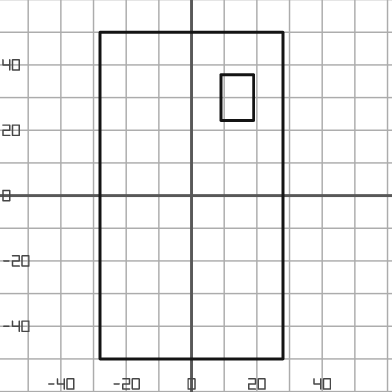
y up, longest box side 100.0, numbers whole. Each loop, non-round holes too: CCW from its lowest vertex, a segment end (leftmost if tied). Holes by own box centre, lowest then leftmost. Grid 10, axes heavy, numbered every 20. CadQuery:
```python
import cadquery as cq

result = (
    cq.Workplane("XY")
    .moveTo(-28.0, -50.0)
    .lineTo(28.0, -50.0)
    .lineTo(28.0, 50.0)
    .lineTo(-28.0, 50.0)
    .close()
    .moveTo(9.0, 23.0)
    .lineTo(19.0, 23.0)
    .lineTo(19.0, 37.0)
    .lineTo(9.0, 37.0)
    .close()
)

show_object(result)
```